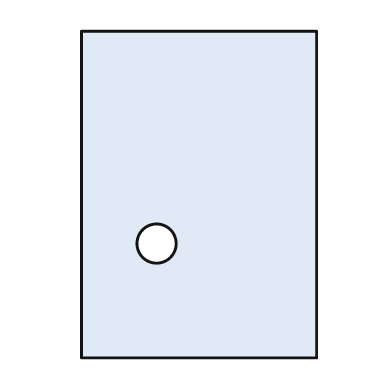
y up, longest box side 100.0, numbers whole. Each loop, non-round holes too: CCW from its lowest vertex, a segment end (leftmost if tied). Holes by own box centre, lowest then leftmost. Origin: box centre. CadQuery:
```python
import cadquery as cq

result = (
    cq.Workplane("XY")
    .moveTo(-36.0, -50.0)
    .lineTo(36.0, -50.0)
    .lineTo(36.0, 50.0)
    .lineTo(-36.0, 50.0)
    .close()
    .moveTo(-13.0, -15.0)
    .circle(6.0)
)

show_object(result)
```